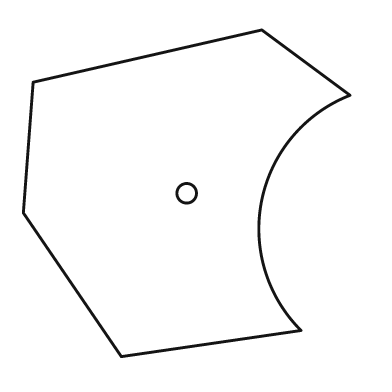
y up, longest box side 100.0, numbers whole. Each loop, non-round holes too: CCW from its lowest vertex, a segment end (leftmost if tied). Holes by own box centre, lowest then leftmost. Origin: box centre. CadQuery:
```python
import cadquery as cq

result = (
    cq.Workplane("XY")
    .moveTo(-20.0, -50.0)
    .lineTo(35.0, -42.0)
    .threePointArc((23.0, -2.0), (50.0, 30.0))
    .lineTo(23.0, 50.0)
    .lineTo(-47.0, 34.0)
    .lineTo(-50.0, -6.0)
    .close()
    .moveTo(0.0, 0.0)
    .circle(3.0)
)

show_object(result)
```